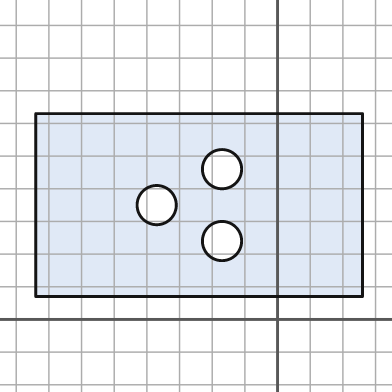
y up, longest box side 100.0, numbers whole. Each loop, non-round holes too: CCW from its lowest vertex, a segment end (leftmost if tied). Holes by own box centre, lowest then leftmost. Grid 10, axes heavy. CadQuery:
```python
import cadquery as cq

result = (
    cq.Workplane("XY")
    .moveTo(-74.0, 7.0)
    .lineTo(26.0, 7.0)
    .lineTo(26.0, 63.0)
    .lineTo(-74.0, 63.0)
    .close()
    .moveTo(-17.0, 24.0)
    .circle(6.0)
    .moveTo(-37.0, 35.0)
    .circle(6.0)
    .moveTo(-17.0, 46.0)
    .circle(6.0)
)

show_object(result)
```